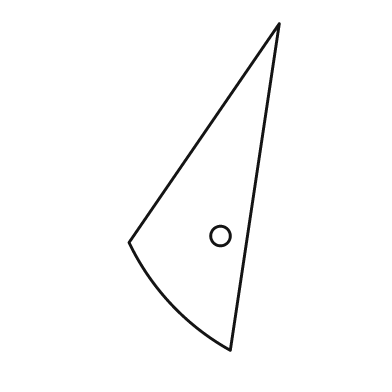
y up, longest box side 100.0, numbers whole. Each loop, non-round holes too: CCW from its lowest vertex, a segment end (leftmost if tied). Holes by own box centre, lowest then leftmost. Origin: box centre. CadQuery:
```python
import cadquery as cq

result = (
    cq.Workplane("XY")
    .moveTo(8.0, -50.0)
    .lineTo(23.0, 50.0)
    .lineTo(-23.0, -17.0)
    .threePointArc((-10.0, -36.0), (8.0, -50.0))
    .close()
    .moveTo(5.0, -15.0)
    .circle(3.0)
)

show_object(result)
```